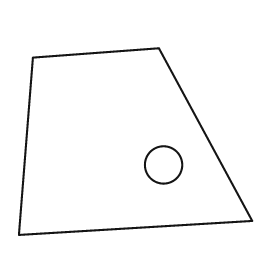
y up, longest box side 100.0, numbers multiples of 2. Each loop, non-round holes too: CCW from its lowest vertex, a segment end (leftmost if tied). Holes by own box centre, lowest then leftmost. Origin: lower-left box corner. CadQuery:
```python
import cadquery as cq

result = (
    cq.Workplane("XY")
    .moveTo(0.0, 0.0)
    .lineTo(100.0, 6.0)
    .lineTo(60.0, 80.0)
    .lineTo(6.0, 76.0)
    .close()
    .moveTo(62.0, 30.0)
    .circle(8.0)
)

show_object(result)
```